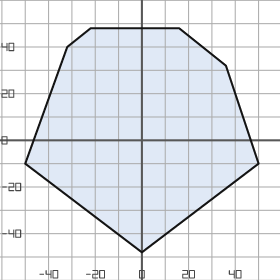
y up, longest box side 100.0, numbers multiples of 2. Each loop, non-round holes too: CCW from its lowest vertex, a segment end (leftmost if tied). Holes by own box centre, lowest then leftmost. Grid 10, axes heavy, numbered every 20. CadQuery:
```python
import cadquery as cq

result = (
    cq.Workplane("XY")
    .moveTo(0.0, -48.0)
    .lineTo(50.0, -10.0)
    .lineTo(36.0, 32.0)
    .lineTo(16.0, 48.0)
    .lineTo(-22.0, 48.0)
    .lineTo(-32.0, 40.0)
    .lineTo(-50.0, -10.0)
    .close()
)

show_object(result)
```